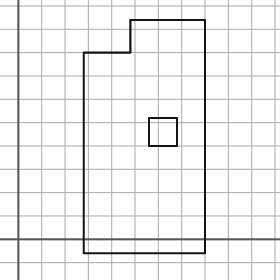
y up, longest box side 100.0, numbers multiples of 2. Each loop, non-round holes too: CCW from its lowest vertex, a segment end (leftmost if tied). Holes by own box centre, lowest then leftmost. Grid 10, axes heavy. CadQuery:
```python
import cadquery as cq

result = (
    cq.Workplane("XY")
    .moveTo(28.0, -6.0)
    .lineTo(80.0, -6.0)
    .lineTo(80.0, 94.0)
    .lineTo(48.0, 94.0)
    .lineTo(48.0, 80.0)
    .lineTo(28.0, 80.0)
    .close()
    .moveTo(56.0, 40.0)
    .lineTo(68.0, 40.0)
    .lineTo(68.0, 52.0)
    .lineTo(56.0, 52.0)
    .close()
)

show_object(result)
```